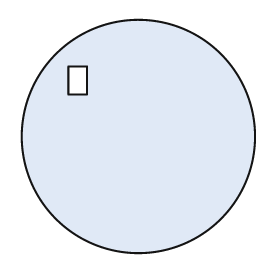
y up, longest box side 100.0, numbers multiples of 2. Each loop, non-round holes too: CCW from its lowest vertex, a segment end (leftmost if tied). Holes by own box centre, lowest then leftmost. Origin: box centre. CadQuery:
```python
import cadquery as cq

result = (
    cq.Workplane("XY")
    .moveTo(0.0, 0.0)
    .circle(50.0)
    .moveTo(-30.0, 18.0)
    .lineTo(-22.0, 18.0)
    .lineTo(-22.0, 30.0)
    .lineTo(-30.0, 30.0)
    .close()
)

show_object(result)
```